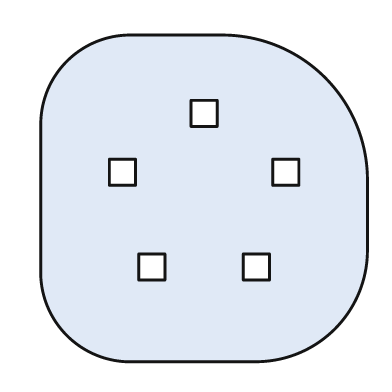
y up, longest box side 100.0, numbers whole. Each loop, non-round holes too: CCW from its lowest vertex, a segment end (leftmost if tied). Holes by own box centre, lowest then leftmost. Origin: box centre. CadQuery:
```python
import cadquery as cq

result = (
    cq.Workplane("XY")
    .moveTo(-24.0, -50.0)
    .lineTo(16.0, -50.0)
    .threePointArc((40.0, -40.0), (50.0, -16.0))
    .lineTo(50.0, 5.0)
    .threePointArc((37.0, 37.0), (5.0, 50.0))
    .lineTo(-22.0, 50.0)
    .threePointArc((-42.0, 42.0), (-50.0, 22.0))
    .lineTo(-50.0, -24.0)
    .threePointArc((-42.0, -42.0), (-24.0, -50.0))
    .close()
    .moveTo(-20.0, -25.0)
    .lineTo(-12.0, -25.0)
    .lineTo(-12.0, -17.0)
    .lineTo(-20.0, -17.0)
    .close()
    .moveTo(12.0, -25.0)
    .lineTo(20.0, -25.0)
    .lineTo(20.0, -17.0)
    .lineTo(12.0, -17.0)
    .close()
    .moveTo(-29.0, 4.0)
    .lineTo(-21.0, 4.0)
    .lineTo(-21.0, 12.0)
    .lineTo(-29.0, 12.0)
    .close()
    .moveTo(21.0, 4.0)
    .lineTo(29.0, 4.0)
    .lineTo(29.0, 12.0)
    .lineTo(21.0, 12.0)
    .close()
    .moveTo(-4.0, 22.0)
    .lineTo(4.0, 22.0)
    .lineTo(4.0, 30.0)
    .lineTo(-4.0, 30.0)
    .close()
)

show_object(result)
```